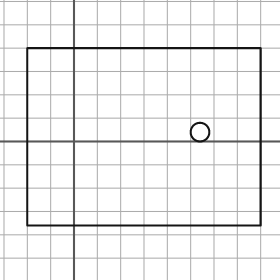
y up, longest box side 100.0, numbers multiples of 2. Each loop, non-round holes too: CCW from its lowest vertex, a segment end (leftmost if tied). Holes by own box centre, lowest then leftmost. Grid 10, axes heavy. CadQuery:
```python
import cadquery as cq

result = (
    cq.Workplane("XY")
    .moveTo(-20.0, -36.0)
    .lineTo(80.0, -36.0)
    .lineTo(80.0, 40.0)
    .lineTo(-20.0, 40.0)
    .close()
    .moveTo(54.0, 4.0)
    .circle(4.0)
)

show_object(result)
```